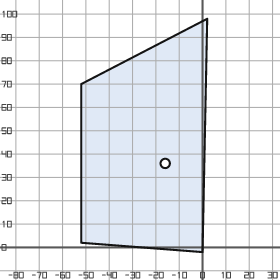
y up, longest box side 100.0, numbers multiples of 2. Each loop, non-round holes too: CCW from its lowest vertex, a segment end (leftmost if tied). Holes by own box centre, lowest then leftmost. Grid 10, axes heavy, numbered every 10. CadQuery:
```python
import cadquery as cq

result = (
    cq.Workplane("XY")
    .moveTo(0.0, -2.0)
    .lineTo(2.0, 98.0)
    .lineTo(-52.0, 70.0)
    .lineTo(-52.0, 2.0)
    .close()
    .moveTo(-16.0, 36.0)
    .circle(2.0)
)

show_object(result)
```